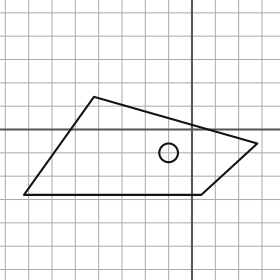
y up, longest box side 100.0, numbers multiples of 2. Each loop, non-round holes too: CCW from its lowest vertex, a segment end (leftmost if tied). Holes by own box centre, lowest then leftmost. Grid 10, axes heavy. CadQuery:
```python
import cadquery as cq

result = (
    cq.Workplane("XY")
    .moveTo(-72.0, -28.0)
    .lineTo(4.0, -28.0)
    .lineTo(28.0, -6.0)
    .lineTo(-42.0, 14.0)
    .close()
    .moveTo(-10.0, -10.0)
    .circle(4.0)
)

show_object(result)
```